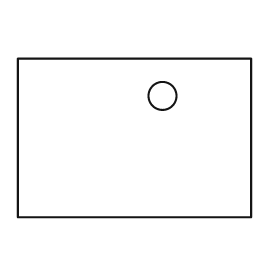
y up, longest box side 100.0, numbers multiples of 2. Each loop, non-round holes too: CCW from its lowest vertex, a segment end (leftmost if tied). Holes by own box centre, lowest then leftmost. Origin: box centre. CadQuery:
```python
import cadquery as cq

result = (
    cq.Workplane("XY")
    .moveTo(-50.0, -34.0)
    .lineTo(50.0, -34.0)
    .lineTo(50.0, 34.0)
    .lineTo(-50.0, 34.0)
    .close()
    .moveTo(12.0, 18.0)
    .circle(6.0)
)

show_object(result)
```